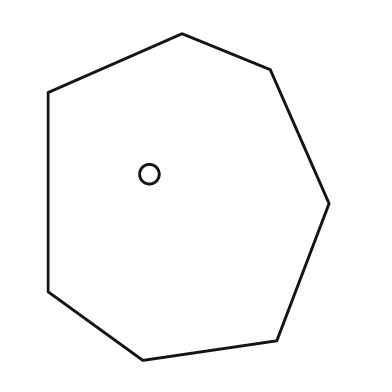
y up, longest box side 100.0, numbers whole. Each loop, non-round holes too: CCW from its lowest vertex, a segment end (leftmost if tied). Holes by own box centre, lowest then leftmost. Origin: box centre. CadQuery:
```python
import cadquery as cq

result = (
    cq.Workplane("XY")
    .moveTo(-14.0, -50.0)
    .lineTo(27.0, -44.0)
    .lineTo(43.0, -2.0)
    .lineTo(25.0, 39.0)
    .lineTo(-2.0, 50.0)
    .lineTo(-43.0, 32.0)
    .lineTo(-43.0, -29.0)
    .close()
    .moveTo(-12.0, 7.0)
    .circle(3.0)
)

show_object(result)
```